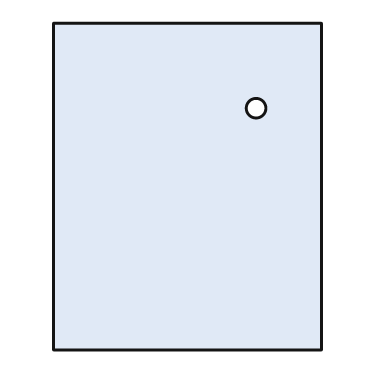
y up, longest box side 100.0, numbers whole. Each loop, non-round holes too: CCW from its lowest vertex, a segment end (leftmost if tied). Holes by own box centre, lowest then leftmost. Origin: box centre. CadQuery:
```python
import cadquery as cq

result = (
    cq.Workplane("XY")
    .moveTo(-41.0, -50.0)
    .lineTo(41.0, -50.0)
    .lineTo(41.0, 50.0)
    .lineTo(-41.0, 50.0)
    .close()
    .moveTo(21.0, 24.0)
    .circle(3.0)
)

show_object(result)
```